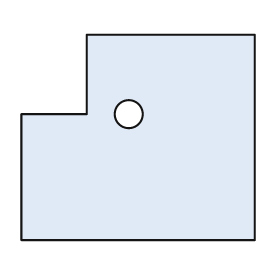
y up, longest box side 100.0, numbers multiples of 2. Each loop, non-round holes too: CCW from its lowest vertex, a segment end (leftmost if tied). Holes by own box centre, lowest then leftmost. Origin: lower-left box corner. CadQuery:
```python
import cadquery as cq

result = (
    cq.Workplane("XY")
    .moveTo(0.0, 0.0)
    .lineTo(100.0, 0.0)
    .lineTo(100.0, 88.0)
    .lineTo(28.0, 88.0)
    .lineTo(28.0, 54.0)
    .lineTo(0.0, 54.0)
    .close()
    .moveTo(46.0, 54.0)
    .circle(6.0)
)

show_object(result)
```